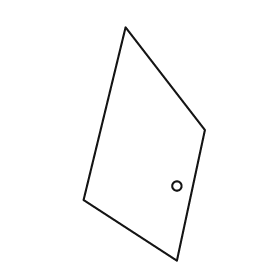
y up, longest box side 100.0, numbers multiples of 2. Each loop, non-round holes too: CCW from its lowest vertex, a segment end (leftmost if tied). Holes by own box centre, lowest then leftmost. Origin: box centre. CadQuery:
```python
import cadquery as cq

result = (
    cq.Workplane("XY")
    .moveTo(14.0, -50.0)
    .lineTo(26.0, 6.0)
    .lineTo(-8.0, 50.0)
    .lineTo(-26.0, -24.0)
    .close()
    .moveTo(14.0, -18.0)
    .circle(2.0)
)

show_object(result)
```